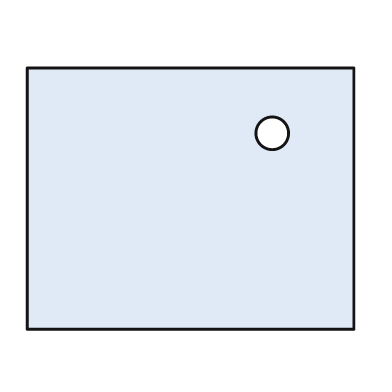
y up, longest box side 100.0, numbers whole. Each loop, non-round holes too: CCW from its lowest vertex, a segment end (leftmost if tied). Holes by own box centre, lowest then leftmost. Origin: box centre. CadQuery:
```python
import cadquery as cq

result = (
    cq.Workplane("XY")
    .moveTo(-50.0, -40.0)
    .lineTo(50.0, -40.0)
    .lineTo(50.0, 40.0)
    .lineTo(-50.0, 40.0)
    .close()
    .moveTo(25.0, 20.0)
    .circle(5.0)
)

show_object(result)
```